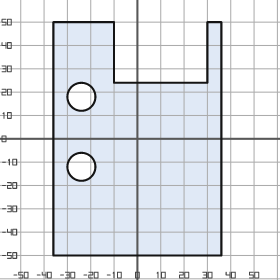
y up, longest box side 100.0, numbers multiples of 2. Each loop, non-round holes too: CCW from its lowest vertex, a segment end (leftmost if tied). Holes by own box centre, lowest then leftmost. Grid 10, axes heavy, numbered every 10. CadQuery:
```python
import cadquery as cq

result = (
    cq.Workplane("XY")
    .moveTo(-36.0, -50.0)
    .lineTo(36.0, -50.0)
    .lineTo(36.0, 50.0)
    .lineTo(30.0, 50.0)
    .lineTo(30.0, 24.0)
    .lineTo(-10.0, 24.0)
    .lineTo(-10.0, 50.0)
    .lineTo(-36.0, 50.0)
    .close()
    .moveTo(-24.0, -12.0)
    .circle(6.0)
    .moveTo(-24.0, 18.0)
    .circle(6.0)
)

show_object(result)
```